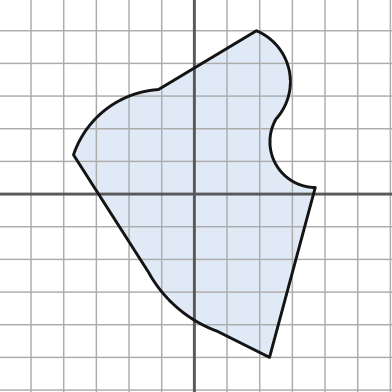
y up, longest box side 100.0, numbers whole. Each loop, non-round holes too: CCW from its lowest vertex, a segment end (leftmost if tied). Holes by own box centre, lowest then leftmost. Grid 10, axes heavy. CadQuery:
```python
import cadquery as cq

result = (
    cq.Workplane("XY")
    .moveTo(23.0, -50.0)
    .lineTo(37.0, 2.0)
    .threePointArc((25.0, 9.0), (25.0, 23.0))
    .threePointArc((29.0, 38.0), (19.0, 50.0))
    .lineTo(-11.0, 32.0)
    .threePointArc((-27.0, 26.0), (-37.0, 12.0))
    .lineTo(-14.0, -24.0)
    .threePointArc((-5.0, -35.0), (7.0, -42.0))
    .close()
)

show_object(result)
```